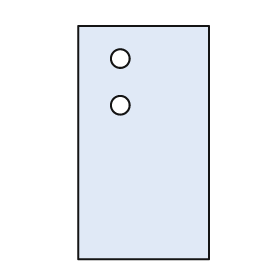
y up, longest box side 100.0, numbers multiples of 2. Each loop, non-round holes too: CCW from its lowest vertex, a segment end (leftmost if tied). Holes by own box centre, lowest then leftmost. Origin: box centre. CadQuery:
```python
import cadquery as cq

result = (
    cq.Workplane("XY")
    .moveTo(-28.0, -50.0)
    .lineTo(28.0, -50.0)
    .lineTo(28.0, 50.0)
    .lineTo(-28.0, 50.0)
    .close()
    .moveTo(-10.0, 16.0)
    .circle(4.0)
    .moveTo(-10.0, 36.0)
    .circle(4.0)
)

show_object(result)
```